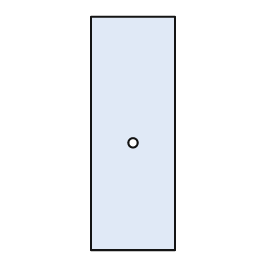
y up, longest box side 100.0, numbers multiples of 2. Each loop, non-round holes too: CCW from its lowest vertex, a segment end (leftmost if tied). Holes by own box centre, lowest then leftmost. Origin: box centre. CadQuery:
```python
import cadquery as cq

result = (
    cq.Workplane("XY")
    .moveTo(-18.0, -50.0)
    .lineTo(18.0, -50.0)
    .lineTo(18.0, 50.0)
    .lineTo(-18.0, 50.0)
    .close()
    .moveTo(0.0, -4.0)
    .circle(2.0)
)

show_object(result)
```